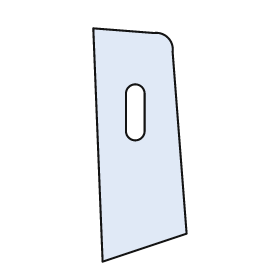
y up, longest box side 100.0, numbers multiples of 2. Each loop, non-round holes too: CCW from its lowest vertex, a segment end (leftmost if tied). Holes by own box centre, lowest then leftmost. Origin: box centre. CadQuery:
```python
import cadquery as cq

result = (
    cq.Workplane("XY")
    .moveTo(-16.0, -50.0)
    .lineTo(20.0, -38.0)
    .lineTo(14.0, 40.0)
    .threePointArc((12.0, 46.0), (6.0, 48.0))
    .lineTo(-20.0, 50.0)
    .close()
    .moveTo(-6.0, 6.0)
    .threePointArc((-2.0, 2.0), (2.0, 6.0))
    .lineTo(2.0, 22.0)
    .threePointArc((-2.0, 26.0), (-6.0, 22.0))
    .close()
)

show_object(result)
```